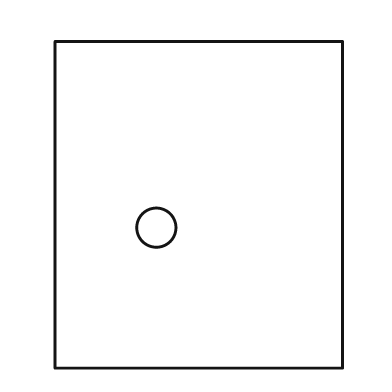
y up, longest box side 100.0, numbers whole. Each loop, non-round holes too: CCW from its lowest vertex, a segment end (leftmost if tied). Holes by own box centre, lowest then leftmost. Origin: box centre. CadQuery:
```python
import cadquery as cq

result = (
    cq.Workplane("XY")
    .moveTo(-44.0, -50.0)
    .lineTo(44.0, -50.0)
    .lineTo(44.0, 50.0)
    .lineTo(-44.0, 50.0)
    .close()
    .moveTo(-13.0, -7.0)
    .circle(6.0)
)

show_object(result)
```